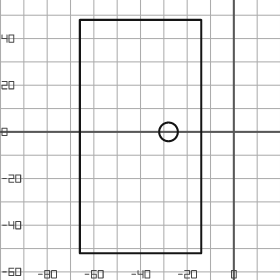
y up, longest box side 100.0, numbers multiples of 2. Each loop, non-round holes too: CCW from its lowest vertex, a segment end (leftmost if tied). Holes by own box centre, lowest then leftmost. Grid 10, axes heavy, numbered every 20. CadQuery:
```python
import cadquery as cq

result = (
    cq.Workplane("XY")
    .moveTo(-66.0, -52.0)
    .lineTo(-14.0, -52.0)
    .lineTo(-14.0, 48.0)
    .lineTo(-66.0, 48.0)
    .close()
    .moveTo(-28.0, 0.0)
    .circle(4.0)
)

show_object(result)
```